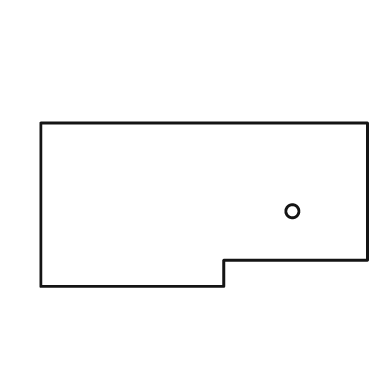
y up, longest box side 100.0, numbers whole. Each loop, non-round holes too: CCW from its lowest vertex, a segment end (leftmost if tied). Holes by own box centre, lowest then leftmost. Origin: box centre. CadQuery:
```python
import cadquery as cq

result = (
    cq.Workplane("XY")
    .moveTo(-50.0, -25.0)
    .lineTo(6.0, -25.0)
    .lineTo(6.0, -17.0)
    .lineTo(50.0, -17.0)
    .lineTo(50.0, 25.0)
    .lineTo(-50.0, 25.0)
    .close()
    .moveTo(27.0, -2.0)
    .circle(2.0)
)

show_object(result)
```